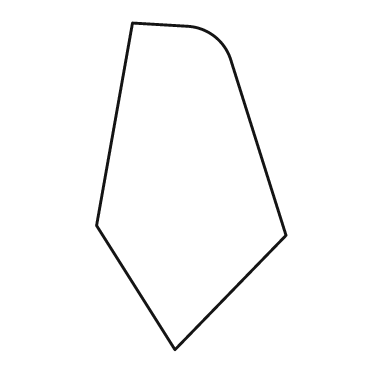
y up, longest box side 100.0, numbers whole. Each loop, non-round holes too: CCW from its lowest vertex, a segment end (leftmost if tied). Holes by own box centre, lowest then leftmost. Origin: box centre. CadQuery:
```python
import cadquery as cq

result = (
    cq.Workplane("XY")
    .moveTo(-5.0, -50.0)
    .lineTo(29.0, -15.0)
    .lineTo(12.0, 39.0)
    .threePointArc((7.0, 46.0), (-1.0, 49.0))
    .lineTo(-18.0, 50.0)
    .lineTo(-29.0, -12.0)
    .close()
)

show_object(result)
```